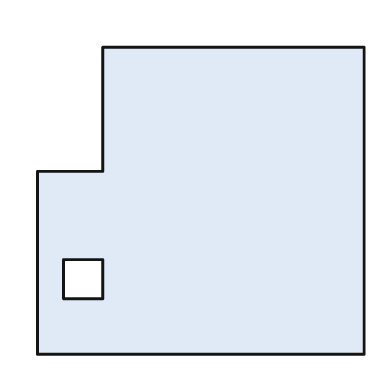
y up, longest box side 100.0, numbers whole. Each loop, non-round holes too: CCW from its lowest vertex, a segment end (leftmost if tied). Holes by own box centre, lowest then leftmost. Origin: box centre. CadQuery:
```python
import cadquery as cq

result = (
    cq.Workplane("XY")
    .moveTo(-50.0, -47.0)
    .lineTo(50.0, -47.0)
    .lineTo(50.0, 47.0)
    .lineTo(-30.0, 47.0)
    .lineTo(-30.0, 9.0)
    .lineTo(-50.0, 9.0)
    .close()
    .moveTo(-42.0, -30.0)
    .lineTo(-30.0, -30.0)
    .lineTo(-30.0, -18.0)
    .lineTo(-42.0, -18.0)
    .close()
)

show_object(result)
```